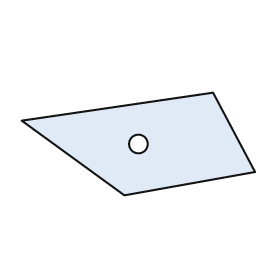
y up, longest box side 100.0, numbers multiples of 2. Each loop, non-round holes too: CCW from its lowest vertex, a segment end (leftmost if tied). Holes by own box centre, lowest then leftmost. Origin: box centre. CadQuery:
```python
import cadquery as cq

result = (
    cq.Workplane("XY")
    .moveTo(-6.0, -22.0)
    .lineTo(50.0, -12.0)
    .lineTo(32.0, 22.0)
    .lineTo(-50.0, 10.0)
    .close()
    .moveTo(0.0, 0.0)
    .circle(4.0)
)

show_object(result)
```